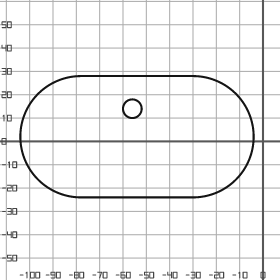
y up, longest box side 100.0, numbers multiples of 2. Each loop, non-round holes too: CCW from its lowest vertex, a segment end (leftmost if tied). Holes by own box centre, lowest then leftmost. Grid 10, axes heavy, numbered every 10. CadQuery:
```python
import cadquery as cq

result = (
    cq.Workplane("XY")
    .moveTo(-78.0, -24.0)
    .lineTo(-30.0, -24.0)
    .threePointArc((-4.0, 2.0), (-30.0, 28.0))
    .lineTo(-78.0, 28.0)
    .threePointArc((-104.0, 2.0), (-78.0, -24.0))
    .close()
    .moveTo(-56.0, 14.0)
    .circle(4.0)
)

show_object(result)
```